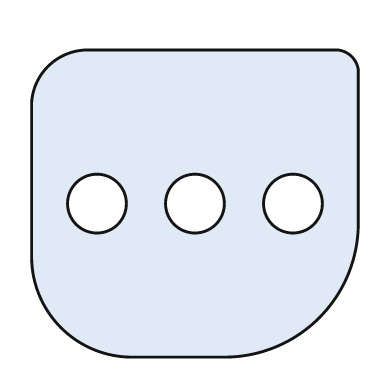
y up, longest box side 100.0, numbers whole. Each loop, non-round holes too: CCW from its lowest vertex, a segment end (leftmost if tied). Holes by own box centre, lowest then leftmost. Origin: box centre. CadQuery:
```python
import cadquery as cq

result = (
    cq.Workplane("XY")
    .moveTo(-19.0, -47.0)
    .lineTo(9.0, -47.0)
    .threePointArc((38.0, -35.0), (50.0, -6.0))
    .lineTo(50.0, 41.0)
    .threePointArc((48.0, 45.0), (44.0, 47.0))
    .lineTo(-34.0, 47.0)
    .threePointArc((-45.0, 42.0), (-50.0, 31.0))
    .lineTo(-50.0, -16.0)
    .threePointArc((-41.0, -38.0), (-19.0, -47.0))
    .close()
    .moveTo(-30.0, 0.0)
    .circle(9.0)
    .moveTo(0.0, 0.0)
    .circle(9.0)
    .moveTo(30.0, 0.0)
    .circle(9.0)
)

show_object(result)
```